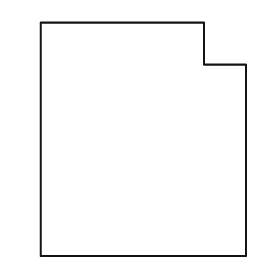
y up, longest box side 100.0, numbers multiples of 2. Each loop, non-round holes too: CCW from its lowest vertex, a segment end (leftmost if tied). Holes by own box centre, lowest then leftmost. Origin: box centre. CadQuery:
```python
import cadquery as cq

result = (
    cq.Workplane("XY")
    .moveTo(-44.0, -50.0)
    .lineTo(44.0, -50.0)
    .lineTo(44.0, 32.0)
    .lineTo(26.0, 32.0)
    .lineTo(26.0, 50.0)
    .lineTo(-44.0, 50.0)
    .close()
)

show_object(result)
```